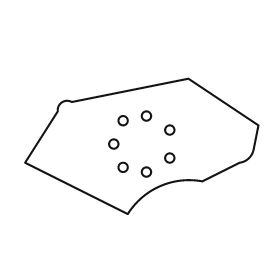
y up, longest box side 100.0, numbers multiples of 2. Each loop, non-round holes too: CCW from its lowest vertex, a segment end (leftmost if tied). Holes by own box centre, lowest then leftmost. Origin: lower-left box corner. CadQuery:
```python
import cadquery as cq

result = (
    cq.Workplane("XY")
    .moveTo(44.0, 0.0)
    .threePointArc((58.0, 12.0), (76.0, 14.0))
    .lineTo(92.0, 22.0)
    .threePointArc((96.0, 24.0), (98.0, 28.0))
    .lineTo(100.0, 38.0)
    .lineTo(70.0, 58.0)
    .lineTo(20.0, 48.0)
    .threePointArc((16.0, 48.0), (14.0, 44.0))
    .lineTo(0.0, 22.0)
    .close()
    .moveTo(52.0, 18.0)
    .circle(2.0)
    .moveTo(42.0, 20.0)
    .circle(2.0)
    .moveTo(62.0, 24.0)
    .circle(2.0)
    .moveTo(38.0, 30.0)
    .circle(2.0)
    .moveTo(62.0, 36.0)
    .circle(2.0)
    .moveTo(42.0, 40.0)
    .circle(2.0)
    .moveTo(52.0, 42.0)
    .circle(2.0)
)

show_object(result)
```